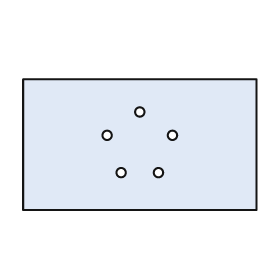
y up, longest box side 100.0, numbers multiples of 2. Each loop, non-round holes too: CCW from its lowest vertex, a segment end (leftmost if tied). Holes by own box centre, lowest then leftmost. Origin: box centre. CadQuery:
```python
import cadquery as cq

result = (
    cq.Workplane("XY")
    .moveTo(-50.0, -28.0)
    .lineTo(50.0, -28.0)
    .lineTo(50.0, 28.0)
    .lineTo(-50.0, 28.0)
    .close()
    .moveTo(-8.0, -12.0)
    .circle(2.0)
    .moveTo(8.0, -12.0)
    .circle(2.0)
    .moveTo(-14.0, 4.0)
    .circle(2.0)
    .moveTo(14.0, 4.0)
    .circle(2.0)
    .moveTo(0.0, 14.0)
    .circle(2.0)
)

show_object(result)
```